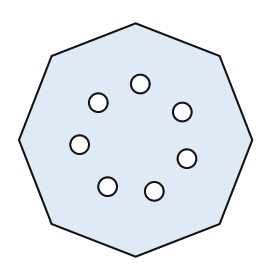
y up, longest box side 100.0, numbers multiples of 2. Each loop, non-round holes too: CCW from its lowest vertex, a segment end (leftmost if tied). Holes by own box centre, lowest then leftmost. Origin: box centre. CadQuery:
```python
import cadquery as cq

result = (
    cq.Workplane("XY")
    .moveTo(0.0, -50.0)
    .lineTo(36.0, -36.0)
    .lineTo(50.0, 0.0)
    .lineTo(36.0, 36.0)
    .lineTo(0.0, 50.0)
    .lineTo(-36.0, 36.0)
    .lineTo(-50.0, 0.0)
    .lineTo(-36.0, -36.0)
    .close()
    .moveTo(8.0, -22.0)
    .circle(4.0)
    .moveTo(-12.0, -20.0)
    .circle(4.0)
    .moveTo(22.0, -8.0)
    .circle(4.0)
    .moveTo(-24.0, -2.0)
    .circle(4.0)
    .moveTo(20.0, 12.0)
    .circle(4.0)
    .moveTo(-16.0, 16.0)
    .circle(4.0)
    .moveTo(2.0, 24.0)
    .circle(4.0)
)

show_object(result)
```